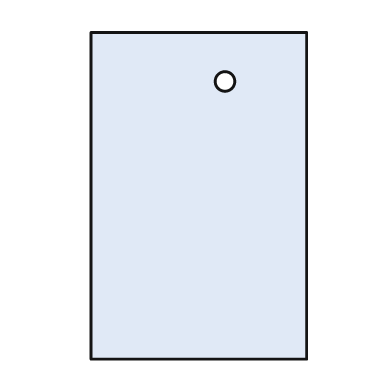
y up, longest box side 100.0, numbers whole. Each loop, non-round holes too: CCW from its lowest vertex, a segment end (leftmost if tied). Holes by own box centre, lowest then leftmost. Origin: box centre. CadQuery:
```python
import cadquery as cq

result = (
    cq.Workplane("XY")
    .moveTo(-33.0, -50.0)
    .lineTo(33.0, -50.0)
    .lineTo(33.0, 50.0)
    .lineTo(-33.0, 50.0)
    .close()
    .moveTo(8.0, 35.0)
    .circle(3.0)
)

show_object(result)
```